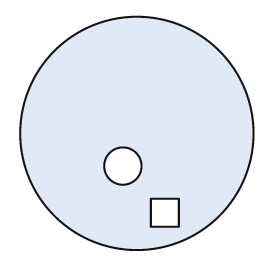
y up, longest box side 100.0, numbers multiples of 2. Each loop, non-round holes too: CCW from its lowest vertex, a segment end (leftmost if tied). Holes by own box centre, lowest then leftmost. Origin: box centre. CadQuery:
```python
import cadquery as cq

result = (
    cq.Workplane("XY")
    .moveTo(0.0, 0.0)
    .circle(50.0)
    .moveTo(6.0, -40.0)
    .lineTo(18.0, -40.0)
    .lineTo(18.0, -28.0)
    .lineTo(6.0, -28.0)
    .close()
    .moveTo(-6.0, -14.0)
    .circle(8.0)
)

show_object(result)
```